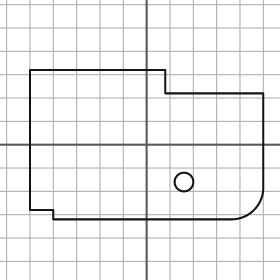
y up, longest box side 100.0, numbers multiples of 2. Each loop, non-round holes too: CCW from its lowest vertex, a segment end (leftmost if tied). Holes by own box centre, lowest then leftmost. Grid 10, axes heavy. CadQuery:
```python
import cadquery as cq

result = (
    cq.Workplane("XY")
    .moveTo(-40.0, -32.0)
    .lineTo(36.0, -32.0)
    .threePointArc((46.0, -28.0), (50.0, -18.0))
    .lineTo(50.0, 22.0)
    .lineTo(8.0, 22.0)
    .lineTo(8.0, 32.0)
    .lineTo(-50.0, 32.0)
    .lineTo(-50.0, -28.0)
    .lineTo(-40.0, -28.0)
    .close()
    .moveTo(16.0, -16.0)
    .circle(4.0)
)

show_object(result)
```